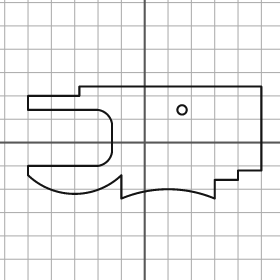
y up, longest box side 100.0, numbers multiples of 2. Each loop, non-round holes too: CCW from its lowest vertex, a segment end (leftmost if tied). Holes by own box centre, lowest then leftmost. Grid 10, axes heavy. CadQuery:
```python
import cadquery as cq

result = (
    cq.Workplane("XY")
    .moveTo(-10.0, -24.0)
    .threePointArc((10.0, -20.0), (30.0, -24.0))
    .lineTo(30.0, -16.0)
    .lineTo(40.0, -16.0)
    .lineTo(40.0, -12.0)
    .lineTo(50.0, -12.0)
    .lineTo(50.0, 24.0)
    .lineTo(-28.0, 24.0)
    .lineTo(-28.0, 20.0)
    .lineTo(-50.0, 20.0)
    .lineTo(-50.0, 14.0)
    .lineTo(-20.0, 14.0)
    .threePointArc((-16.0, 12.0), (-14.0, 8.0))
    .lineTo(-14.0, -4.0)
    .threePointArc((-16.0, -8.0), (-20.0, -10.0))
    .lineTo(-50.0, -10.0)
    .lineTo(-50.0, -14.0)
    .threePointArc((-30.0, -22.0), (-10.0, -14.0))
    .close()
    .moveTo(16.0, 14.0)
    .circle(2.0)
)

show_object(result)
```